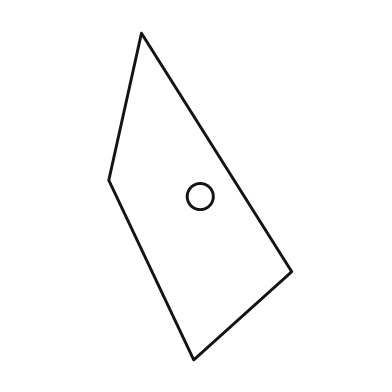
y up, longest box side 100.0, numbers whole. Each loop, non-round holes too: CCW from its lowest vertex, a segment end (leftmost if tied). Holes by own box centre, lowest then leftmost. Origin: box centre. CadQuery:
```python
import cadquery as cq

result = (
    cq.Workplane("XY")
    .moveTo(-2.0, -50.0)
    .lineTo(28.0, -23.0)
    .lineTo(-18.0, 50.0)
    .lineTo(-28.0, 5.0)
    .close()
    .moveTo(0.0, 0.0)
    .circle(4.0)
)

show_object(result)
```